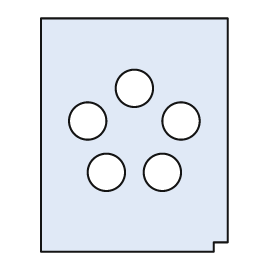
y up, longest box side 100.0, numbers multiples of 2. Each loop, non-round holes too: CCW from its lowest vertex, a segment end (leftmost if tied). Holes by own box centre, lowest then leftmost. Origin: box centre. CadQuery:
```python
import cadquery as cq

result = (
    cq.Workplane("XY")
    .moveTo(-40.0, -50.0)
    .lineTo(34.0, -50.0)
    .lineTo(34.0, -46.0)
    .lineTo(40.0, -46.0)
    .lineTo(40.0, 50.0)
    .lineTo(-40.0, 50.0)
    .close()
    .moveTo(-12.0, -16.0)
    .circle(8.0)
    .moveTo(12.0, -16.0)
    .circle(8.0)
    .moveTo(-20.0, 6.0)
    .circle(8.0)
    .moveTo(20.0, 6.0)
    .circle(8.0)
    .moveTo(0.0, 20.0)
    .circle(8.0)
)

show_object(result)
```